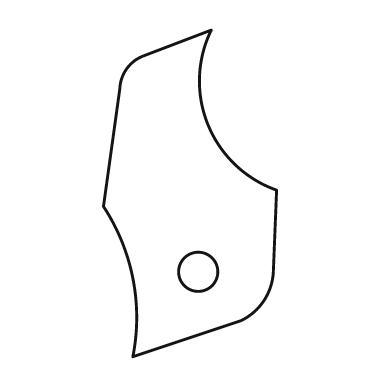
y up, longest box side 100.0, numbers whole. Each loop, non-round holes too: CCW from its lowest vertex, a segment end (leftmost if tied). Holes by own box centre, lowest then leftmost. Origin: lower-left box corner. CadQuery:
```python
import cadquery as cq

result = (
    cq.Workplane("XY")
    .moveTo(9.0, 0.0)
    .lineTo(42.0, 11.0)
    .threePointArc((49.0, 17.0), (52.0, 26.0))
    .lineTo(53.0, 51.0)
    .threePointArc((32.0, 71.0), (33.0, 100.0))
    .lineTo(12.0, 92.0)
    .threePointArc((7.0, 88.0), (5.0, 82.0))
    .lineTo(0.0, 46.0)
    .threePointArc((9.0, 24.0), (9.0, 0.0))
    .close()
    .moveTo(29.0, 26.0)
    .circle(6.0)
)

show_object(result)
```